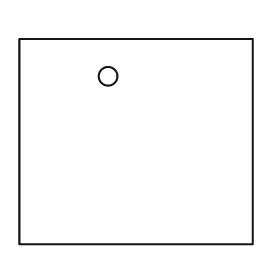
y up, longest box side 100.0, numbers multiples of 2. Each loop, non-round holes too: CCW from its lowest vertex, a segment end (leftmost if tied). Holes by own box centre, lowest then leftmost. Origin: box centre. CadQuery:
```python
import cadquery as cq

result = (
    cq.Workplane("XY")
    .moveTo(-50.0, -44.0)
    .lineTo(50.0, -44.0)
    .lineTo(50.0, 44.0)
    .lineTo(-50.0, 44.0)
    .close()
    .moveTo(-12.0, 28.0)
    .circle(4.0)
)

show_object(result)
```